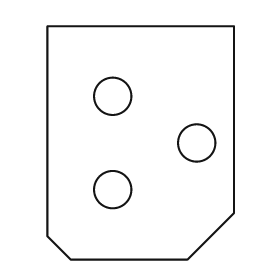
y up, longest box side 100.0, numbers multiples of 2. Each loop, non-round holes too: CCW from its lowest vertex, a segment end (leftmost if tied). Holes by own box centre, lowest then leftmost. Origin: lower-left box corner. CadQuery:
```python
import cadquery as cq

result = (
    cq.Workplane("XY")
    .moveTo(10.0, 0.0)
    .lineTo(60.0, 0.0)
    .lineTo(80.0, 20.0)
    .lineTo(80.0, 100.0)
    .lineTo(0.0, 100.0)
    .lineTo(0.0, 10.0)
    .close()
    .moveTo(28.0, 30.0)
    .circle(8.0)
    .moveTo(64.0, 50.0)
    .circle(8.0)
    .moveTo(28.0, 70.0)
    .circle(8.0)
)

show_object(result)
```